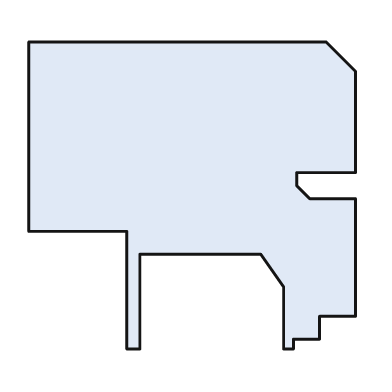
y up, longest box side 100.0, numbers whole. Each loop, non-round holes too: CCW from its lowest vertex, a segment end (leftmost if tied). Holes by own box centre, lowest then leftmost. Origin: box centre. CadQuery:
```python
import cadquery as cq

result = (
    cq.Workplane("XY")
    .moveTo(-20.0, -47.0)
    .lineTo(-16.0, -47.0)
    .lineTo(-16.0, -18.0)
    .lineTo(21.0, -18.0)
    .lineTo(28.0, -28.0)
    .lineTo(28.0, -47.0)
    .lineTo(31.0, -47.0)
    .lineTo(31.0, -44.0)
    .lineTo(39.0, -44.0)
    .lineTo(39.0, -37.0)
    .lineTo(50.0, -37.0)
    .lineTo(50.0, -1.0)
    .lineTo(36.0, -1.0)
    .lineTo(32.0, 3.0)
    .lineTo(32.0, 7.0)
    .lineTo(50.0, 7.0)
    .lineTo(50.0, 38.0)
    .lineTo(41.0, 47.0)
    .lineTo(-50.0, 47.0)
    .lineTo(-50.0, -11.0)
    .lineTo(-20.0, -11.0)
    .close()
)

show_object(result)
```